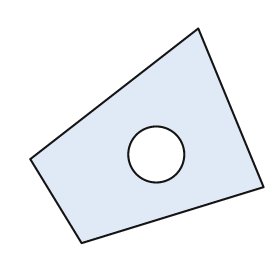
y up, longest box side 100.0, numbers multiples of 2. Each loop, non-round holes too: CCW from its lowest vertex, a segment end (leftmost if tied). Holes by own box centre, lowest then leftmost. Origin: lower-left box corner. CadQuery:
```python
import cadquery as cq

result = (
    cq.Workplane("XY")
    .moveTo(22.0, 0.0)
    .lineTo(100.0, 24.0)
    .lineTo(72.0, 92.0)
    .lineTo(0.0, 36.0)
    .close()
    .moveTo(54.0, 38.0)
    .circle(12.0)
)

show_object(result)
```